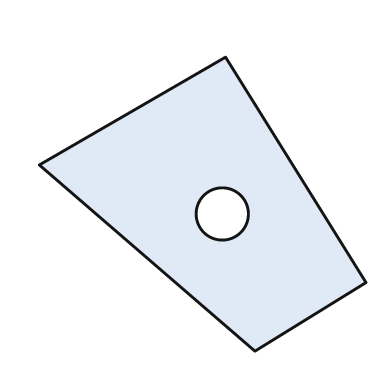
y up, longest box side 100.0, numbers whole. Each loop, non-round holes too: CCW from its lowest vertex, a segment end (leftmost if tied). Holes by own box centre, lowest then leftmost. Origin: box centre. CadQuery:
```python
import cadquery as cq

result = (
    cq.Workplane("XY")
    .moveTo(16.0, -45.0)
    .lineTo(50.0, -24.0)
    .lineTo(7.0, 45.0)
    .lineTo(-50.0, 12.0)
    .close()
    .moveTo(6.0, -3.0)
    .circle(8.0)
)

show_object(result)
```